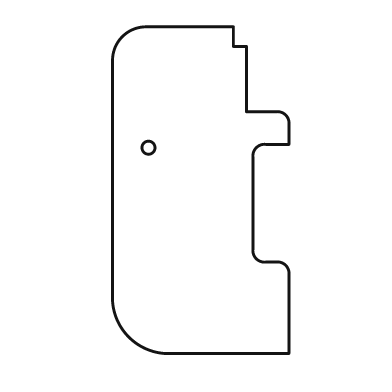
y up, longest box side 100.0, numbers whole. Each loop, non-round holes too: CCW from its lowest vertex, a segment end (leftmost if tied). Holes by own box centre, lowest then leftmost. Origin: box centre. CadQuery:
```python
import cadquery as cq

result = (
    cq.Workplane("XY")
    .moveTo(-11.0, -50.0)
    .lineTo(27.0, -50.0)
    .lineTo(27.0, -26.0)
    .threePointArc((26.0, -23.0), (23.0, -22.0))
    .lineTo(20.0, -22.0)
    .threePointArc((17.0, -21.0), (16.0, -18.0))
    .lineTo(16.0, 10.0)
    .threePointArc((17.0, 13.0), (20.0, 14.0))
    .lineTo(27.0, 14.0)
    .lineTo(27.0, 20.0)
    .threePointArc((26.0, 23.0), (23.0, 24.0))
    .lineTo(14.0, 24.0)
    .lineTo(14.0, 44.0)
    .lineTo(10.0, 44.0)
    .lineTo(10.0, 50.0)
    .lineTo(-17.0, 50.0)
    .threePointArc((-24.0, 47.0), (-27.0, 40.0))
    .lineTo(-27.0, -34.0)
    .threePointArc((-22.0, -45.0), (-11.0, -50.0))
    .close()
    .moveTo(-16.0, 13.0)
    .circle(2.0)
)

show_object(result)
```